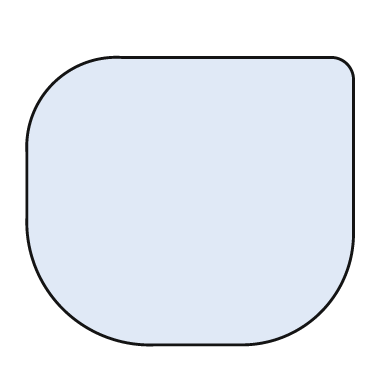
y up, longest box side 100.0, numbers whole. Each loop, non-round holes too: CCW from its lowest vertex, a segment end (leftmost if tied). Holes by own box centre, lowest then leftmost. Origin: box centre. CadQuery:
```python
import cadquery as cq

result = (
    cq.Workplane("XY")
    .moveTo(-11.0, -44.0)
    .lineTo(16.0, -44.0)
    .threePointArc((40.0, -34.0), (50.0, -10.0))
    .lineTo(50.0, 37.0)
    .threePointArc((48.0, 42.0), (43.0, 44.0))
    .lineTo(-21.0, 44.0)
    .threePointArc((-42.0, 36.0), (-50.0, 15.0))
    .lineTo(-50.0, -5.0)
    .threePointArc((-39.0, -33.0), (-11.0, -44.0))
    .close()
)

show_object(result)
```